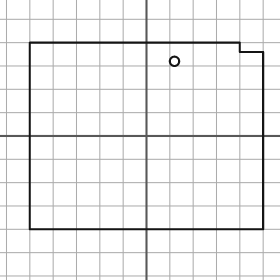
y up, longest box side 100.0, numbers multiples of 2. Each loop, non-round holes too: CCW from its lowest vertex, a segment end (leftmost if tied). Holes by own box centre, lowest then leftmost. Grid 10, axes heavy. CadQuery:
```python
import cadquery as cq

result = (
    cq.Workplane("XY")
    .moveTo(-50.0, -40.0)
    .lineTo(50.0, -40.0)
    .lineTo(50.0, 36.0)
    .lineTo(40.0, 36.0)
    .lineTo(40.0, 40.0)
    .lineTo(-50.0, 40.0)
    .close()
    .moveTo(12.0, 32.0)
    .circle(2.0)
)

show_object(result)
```